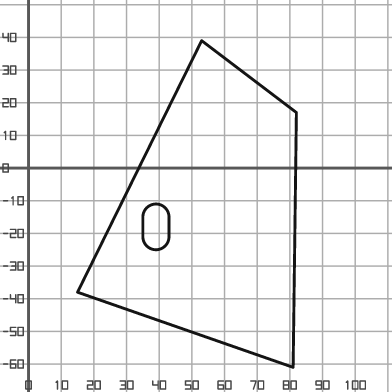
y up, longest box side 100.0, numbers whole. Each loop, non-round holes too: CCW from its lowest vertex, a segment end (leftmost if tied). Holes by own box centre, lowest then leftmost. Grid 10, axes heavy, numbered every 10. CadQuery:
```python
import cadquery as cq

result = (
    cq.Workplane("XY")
    .moveTo(81.0, -61.0)
    .lineTo(82.0, 17.0)
    .lineTo(53.0, 39.0)
    .lineTo(15.0, -38.0)
    .close()
    .moveTo(35.0, -21.0)
    .threePointArc((39.0, -25.0), (43.0, -21.0))
    .lineTo(43.0, -15.0)
    .threePointArc((39.0, -11.0), (35.0, -15.0))
    .close()
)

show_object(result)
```